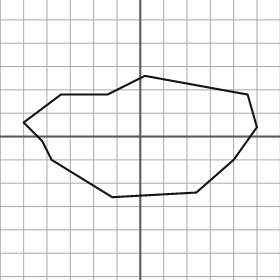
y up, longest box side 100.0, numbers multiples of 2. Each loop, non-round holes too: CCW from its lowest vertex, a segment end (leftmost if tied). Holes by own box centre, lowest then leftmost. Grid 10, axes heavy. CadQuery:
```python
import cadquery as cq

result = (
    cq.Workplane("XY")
    .moveTo(-12.0, -26.0)
    .lineTo(24.0, -24.0)
    .lineTo(40.0, -10.0)
    .lineTo(50.0, 4.0)
    .lineTo(46.0, 18.0)
    .lineTo(2.0, 26.0)
    .lineTo(-14.0, 18.0)
    .lineTo(-34.0, 18.0)
    .lineTo(-50.0, 6.0)
    .lineTo(-42.0, -2.0)
    .lineTo(-38.0, -10.0)
    .close()
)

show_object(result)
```